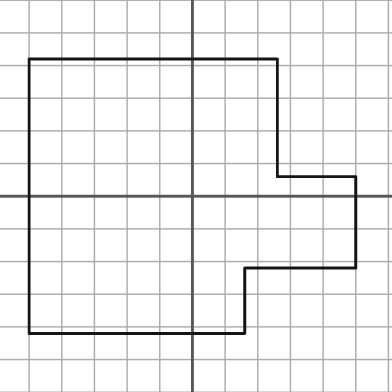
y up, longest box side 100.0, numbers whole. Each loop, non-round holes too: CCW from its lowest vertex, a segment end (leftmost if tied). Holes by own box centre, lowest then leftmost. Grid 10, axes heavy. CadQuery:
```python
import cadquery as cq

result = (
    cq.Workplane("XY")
    .moveTo(-50.0, -42.0)
    .lineTo(16.0, -42.0)
    .lineTo(16.0, -22.0)
    .lineTo(50.0, -22.0)
    .lineTo(50.0, 6.0)
    .lineTo(26.0, 6.0)
    .lineTo(26.0, 42.0)
    .lineTo(-50.0, 42.0)
    .close()
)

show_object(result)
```